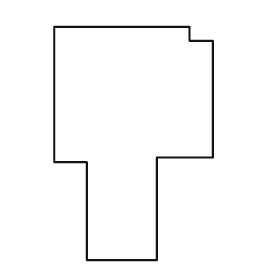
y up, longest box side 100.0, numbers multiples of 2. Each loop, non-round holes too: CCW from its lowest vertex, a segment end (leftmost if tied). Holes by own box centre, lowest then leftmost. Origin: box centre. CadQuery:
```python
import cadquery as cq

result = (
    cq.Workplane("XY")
    .moveTo(-20.0, -50.0)
    .lineTo(10.0, -50.0)
    .lineTo(10.0, -6.0)
    .lineTo(34.0, -6.0)
    .lineTo(34.0, 44.0)
    .lineTo(24.0, 44.0)
    .lineTo(24.0, 50.0)
    .lineTo(-34.0, 50.0)
    .lineTo(-34.0, -8.0)
    .lineTo(-20.0, -8.0)
    .close()
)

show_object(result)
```